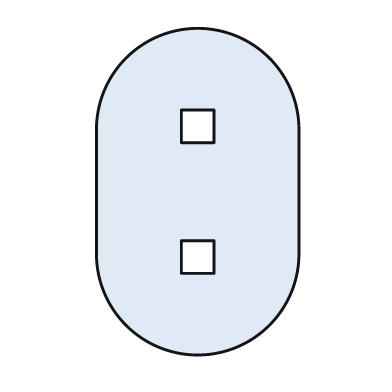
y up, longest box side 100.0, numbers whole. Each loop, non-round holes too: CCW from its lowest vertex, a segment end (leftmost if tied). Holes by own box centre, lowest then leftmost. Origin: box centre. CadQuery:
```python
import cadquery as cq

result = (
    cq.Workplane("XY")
    .moveTo(-31.0, -19.0)
    .threePointArc((0.0, -50.0), (31.0, -19.0))
    .lineTo(31.0, 19.0)
    .threePointArc((0.0, 50.0), (-31.0, 19.0))
    .close()
    .moveTo(-5.0, -25.0)
    .lineTo(5.0, -25.0)
    .lineTo(5.0, -15.0)
    .lineTo(-5.0, -15.0)
    .close()
    .moveTo(-5.0, 15.0)
    .lineTo(5.0, 15.0)
    .lineTo(5.0, 25.0)
    .lineTo(-5.0, 25.0)
    .close()
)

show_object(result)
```